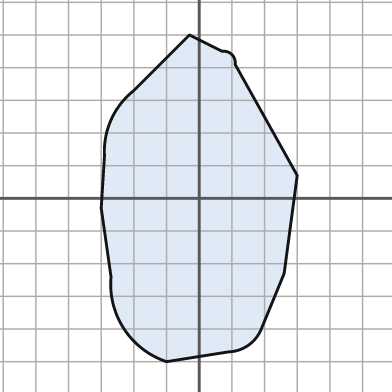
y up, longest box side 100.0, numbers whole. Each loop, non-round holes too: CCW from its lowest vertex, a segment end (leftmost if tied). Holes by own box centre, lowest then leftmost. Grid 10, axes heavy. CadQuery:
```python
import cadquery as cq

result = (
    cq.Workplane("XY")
    .moveTo(-10.0, -50.0)
    .lineTo(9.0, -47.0)
    .threePointArc((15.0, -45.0), (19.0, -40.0))
    .lineTo(26.0, -23.0)
    .lineTo(30.0, 7.0)
    .lineTo(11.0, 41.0)
    .threePointArc((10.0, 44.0), (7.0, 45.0))
    .lineTo(-3.0, 50.0)
    .lineTo(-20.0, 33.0)
    .threePointArc((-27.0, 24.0), (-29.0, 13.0))
    .lineTo(-30.0, -3.0)
    .lineTo(-27.0, -24.0)
    .threePointArc((-23.0, -40.0), (-10.0, -50.0))
    .close()
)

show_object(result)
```